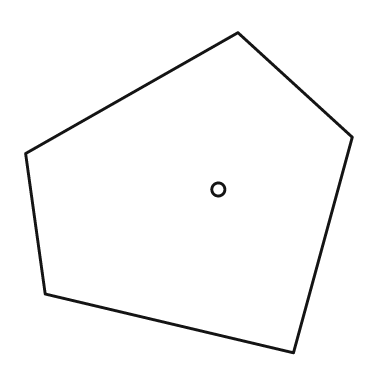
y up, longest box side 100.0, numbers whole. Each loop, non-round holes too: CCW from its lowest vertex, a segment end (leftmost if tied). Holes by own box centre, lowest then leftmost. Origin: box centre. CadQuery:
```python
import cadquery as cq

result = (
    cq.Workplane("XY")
    .moveTo(32.0, -49.0)
    .lineTo(50.0, 17.0)
    .lineTo(15.0, 49.0)
    .lineTo(-50.0, 12.0)
    .lineTo(-44.0, -31.0)
    .close()
    .moveTo(9.0, 1.0)
    .circle(2.0)
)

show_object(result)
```